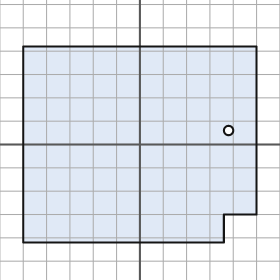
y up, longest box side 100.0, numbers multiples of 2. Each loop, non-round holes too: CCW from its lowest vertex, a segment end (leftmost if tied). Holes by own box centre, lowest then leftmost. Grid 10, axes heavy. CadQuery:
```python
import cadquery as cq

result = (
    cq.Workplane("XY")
    .moveTo(-50.0, -42.0)
    .lineTo(36.0, -42.0)
    .lineTo(36.0, -30.0)
    .lineTo(50.0, -30.0)
    .lineTo(50.0, 42.0)
    .lineTo(-50.0, 42.0)
    .close()
    .moveTo(38.0, 6.0)
    .circle(2.0)
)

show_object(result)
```